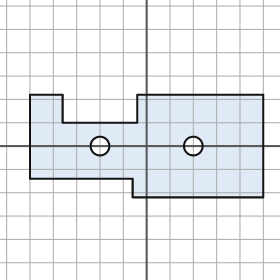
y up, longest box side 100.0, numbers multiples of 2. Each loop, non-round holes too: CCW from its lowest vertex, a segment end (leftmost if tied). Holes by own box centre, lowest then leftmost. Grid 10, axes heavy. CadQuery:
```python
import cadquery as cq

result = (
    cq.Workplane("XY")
    .moveTo(-6.0, -22.0)
    .lineTo(50.0, -22.0)
    .lineTo(50.0, 22.0)
    .lineTo(-4.0, 22.0)
    .lineTo(-4.0, 10.0)
    .lineTo(-36.0, 10.0)
    .lineTo(-36.0, 22.0)
    .lineTo(-50.0, 22.0)
    .lineTo(-50.0, -14.0)
    .lineTo(-6.0, -14.0)
    .close()
    .moveTo(-20.0, 0.0)
    .circle(4.0)
    .moveTo(20.0, 0.0)
    .circle(4.0)
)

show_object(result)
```